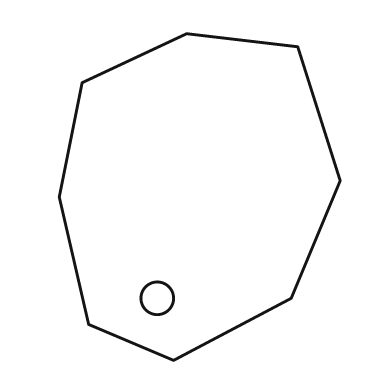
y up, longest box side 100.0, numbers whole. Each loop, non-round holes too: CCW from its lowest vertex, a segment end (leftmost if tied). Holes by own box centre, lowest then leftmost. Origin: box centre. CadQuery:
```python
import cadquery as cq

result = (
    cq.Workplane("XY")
    .moveTo(-8.0, -50.0)
    .lineTo(28.0, -31.0)
    .lineTo(43.0, 5.0)
    .lineTo(30.0, 46.0)
    .lineTo(-4.0, 50.0)
    .lineTo(-36.0, 35.0)
    .lineTo(-43.0, 0.0)
    .lineTo(-34.0, -39.0)
    .close()
    .moveTo(-13.0, -31.0)
    .circle(5.0)
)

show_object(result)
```